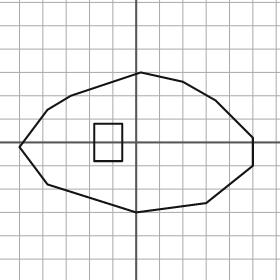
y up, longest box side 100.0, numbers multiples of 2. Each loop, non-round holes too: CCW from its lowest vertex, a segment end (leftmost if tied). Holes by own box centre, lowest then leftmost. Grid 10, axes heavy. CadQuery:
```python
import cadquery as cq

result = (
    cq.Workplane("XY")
    .moveTo(0.0, -30.0)
    .lineTo(30.0, -26.0)
    .lineTo(50.0, -10.0)
    .lineTo(50.0, 2.0)
    .lineTo(34.0, 18.0)
    .lineTo(20.0, 26.0)
    .lineTo(2.0, 30.0)
    .lineTo(-28.0, 20.0)
    .lineTo(-38.0, 14.0)
    .lineTo(-50.0, -2.0)
    .lineTo(-38.0, -18.0)
    .close()
    .moveTo(-18.0, -8.0)
    .lineTo(-6.0, -8.0)
    .lineTo(-6.0, 8.0)
    .lineTo(-18.0, 8.0)
    .close()
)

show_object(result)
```